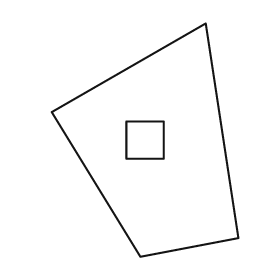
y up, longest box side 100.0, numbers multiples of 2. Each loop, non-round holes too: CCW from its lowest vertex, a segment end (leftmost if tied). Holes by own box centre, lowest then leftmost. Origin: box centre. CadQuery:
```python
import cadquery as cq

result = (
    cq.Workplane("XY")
    .moveTo(-2.0, -50.0)
    .lineTo(40.0, -42.0)
    .lineTo(26.0, 50.0)
    .lineTo(-40.0, 12.0)
    .close()
    .moveTo(-8.0, -8.0)
    .lineTo(8.0, -8.0)
    .lineTo(8.0, 8.0)
    .lineTo(-8.0, 8.0)
    .close()
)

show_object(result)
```